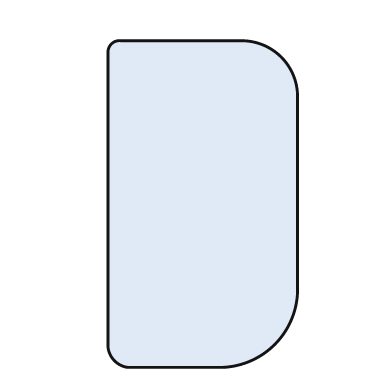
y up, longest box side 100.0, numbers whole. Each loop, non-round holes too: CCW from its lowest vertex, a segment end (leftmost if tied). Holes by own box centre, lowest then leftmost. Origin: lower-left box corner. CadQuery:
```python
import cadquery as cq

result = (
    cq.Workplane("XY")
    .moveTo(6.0, 0.0)
    .lineTo(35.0, 0.0)
    .threePointArc((51.0, 7.0), (58.0, 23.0))
    .lineTo(58.0, 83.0)
    .threePointArc((53.0, 95.0), (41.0, 100.0))
    .lineTo(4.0, 100.0)
    .threePointArc((1.0, 99.0), (0.0, 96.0))
    .lineTo(0.0, 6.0)
    .threePointArc((2.0, 2.0), (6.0, 0.0))
    .close()
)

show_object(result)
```